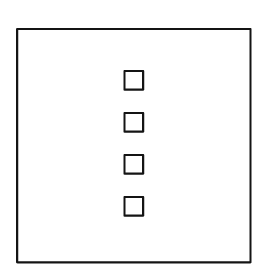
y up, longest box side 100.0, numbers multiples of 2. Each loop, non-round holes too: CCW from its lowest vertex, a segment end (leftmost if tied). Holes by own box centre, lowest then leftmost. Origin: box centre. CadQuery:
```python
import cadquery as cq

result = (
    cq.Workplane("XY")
    .moveTo(-50.0, -50.0)
    .lineTo(50.0, -50.0)
    .lineTo(50.0, 50.0)
    .lineTo(-50.0, 50.0)
    .close()
    .moveTo(-4.0, -30.0)
    .lineTo(4.0, -30.0)
    .lineTo(4.0, -22.0)
    .lineTo(-4.0, -22.0)
    .close()
    .moveTo(-4.0, -12.0)
    .lineTo(4.0, -12.0)
    .lineTo(4.0, -4.0)
    .lineTo(-4.0, -4.0)
    .close()
    .moveTo(-4.0, 6.0)
    .lineTo(4.0, 6.0)
    .lineTo(4.0, 14.0)
    .lineTo(-4.0, 14.0)
    .close()
    .moveTo(-4.0, 24.0)
    .lineTo(4.0, 24.0)
    .lineTo(4.0, 32.0)
    .lineTo(-4.0, 32.0)
    .close()
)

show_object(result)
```